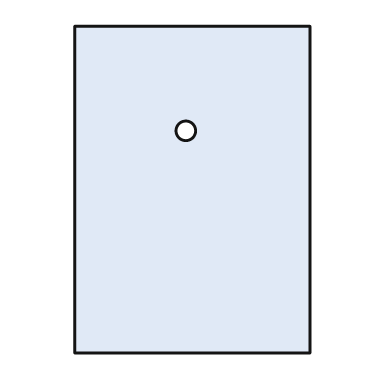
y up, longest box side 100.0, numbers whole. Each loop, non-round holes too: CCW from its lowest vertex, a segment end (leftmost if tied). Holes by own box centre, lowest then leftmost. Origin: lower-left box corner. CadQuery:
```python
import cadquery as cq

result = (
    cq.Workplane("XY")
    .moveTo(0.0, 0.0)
    .lineTo(72.0, 0.0)
    .lineTo(72.0, 100.0)
    .lineTo(0.0, 100.0)
    .close()
    .moveTo(34.0, 68.0)
    .circle(3.0)
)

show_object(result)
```